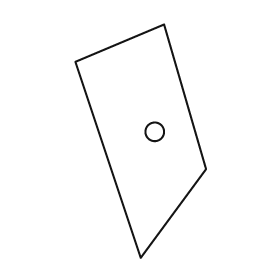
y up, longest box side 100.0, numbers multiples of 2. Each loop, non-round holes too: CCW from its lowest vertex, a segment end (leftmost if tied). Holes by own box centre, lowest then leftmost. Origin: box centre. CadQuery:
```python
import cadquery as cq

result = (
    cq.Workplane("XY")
    .moveTo(0.0, -50.0)
    .lineTo(28.0, -12.0)
    .lineTo(10.0, 50.0)
    .lineTo(-28.0, 34.0)
    .close()
    .moveTo(6.0, 4.0)
    .circle(4.0)
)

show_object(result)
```